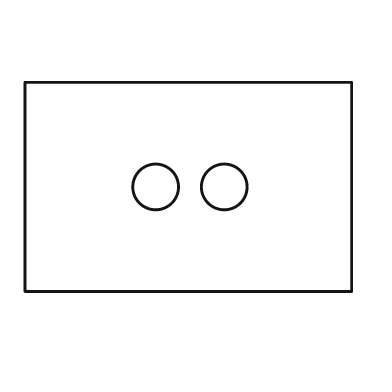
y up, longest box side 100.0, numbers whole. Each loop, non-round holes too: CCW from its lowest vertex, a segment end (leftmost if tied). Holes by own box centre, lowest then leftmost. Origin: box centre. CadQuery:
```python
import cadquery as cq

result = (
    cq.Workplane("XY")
    .moveTo(-50.0, -32.0)
    .lineTo(50.0, -32.0)
    .lineTo(50.0, 32.0)
    .lineTo(-50.0, 32.0)
    .close()
    .moveTo(-10.0, 0.0)
    .circle(7.0)
    .moveTo(11.0, 0.0)
    .circle(7.0)
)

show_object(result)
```